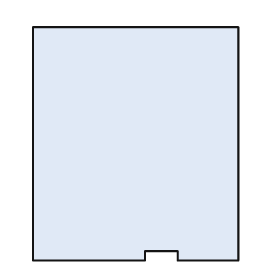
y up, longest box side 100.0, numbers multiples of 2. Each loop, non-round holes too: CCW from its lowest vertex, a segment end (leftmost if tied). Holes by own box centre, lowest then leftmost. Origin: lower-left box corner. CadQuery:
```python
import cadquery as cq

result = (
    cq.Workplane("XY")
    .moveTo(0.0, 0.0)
    .lineTo(48.0, 0.0)
    .lineTo(48.0, 4.0)
    .lineTo(62.0, 4.0)
    .lineTo(62.0, 0.0)
    .lineTo(88.0, 0.0)
    .lineTo(88.0, 100.0)
    .lineTo(0.0, 100.0)
    .close()
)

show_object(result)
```